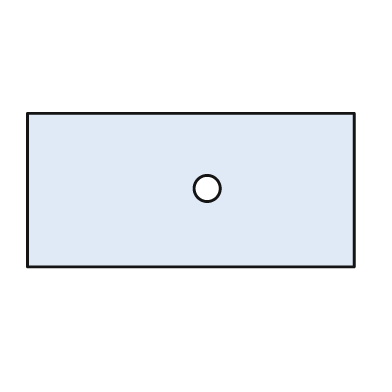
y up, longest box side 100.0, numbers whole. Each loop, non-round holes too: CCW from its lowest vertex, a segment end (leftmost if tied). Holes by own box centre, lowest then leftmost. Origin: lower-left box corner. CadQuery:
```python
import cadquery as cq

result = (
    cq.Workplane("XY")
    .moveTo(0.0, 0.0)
    .lineTo(100.0, 0.0)
    .lineTo(100.0, 47.0)
    .lineTo(0.0, 47.0)
    .close()
    .moveTo(55.0, 24.0)
    .circle(4.0)
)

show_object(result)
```